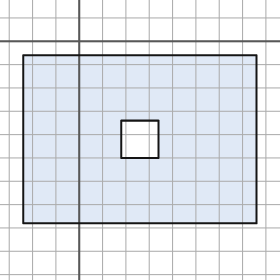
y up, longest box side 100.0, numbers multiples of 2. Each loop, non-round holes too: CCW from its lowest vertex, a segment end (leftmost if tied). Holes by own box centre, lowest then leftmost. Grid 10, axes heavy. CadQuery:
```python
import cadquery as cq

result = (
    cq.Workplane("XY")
    .moveTo(-24.0, -78.0)
    .lineTo(76.0, -78.0)
    .lineTo(76.0, -6.0)
    .lineTo(-24.0, -6.0)
    .close()
    .moveTo(18.0, -50.0)
    .lineTo(34.0, -50.0)
    .lineTo(34.0, -34.0)
    .lineTo(18.0, -34.0)
    .close()
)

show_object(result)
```